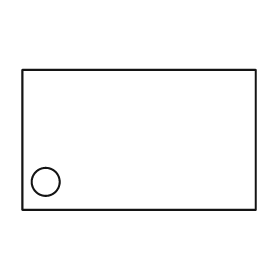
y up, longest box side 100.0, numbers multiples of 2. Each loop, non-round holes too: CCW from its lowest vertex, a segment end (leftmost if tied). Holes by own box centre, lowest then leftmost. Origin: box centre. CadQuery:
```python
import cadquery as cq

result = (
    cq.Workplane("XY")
    .moveTo(-50.0, -30.0)
    .lineTo(50.0, -30.0)
    .lineTo(50.0, 30.0)
    .lineTo(-50.0, 30.0)
    .close()
    .moveTo(-40.0, -18.0)
    .circle(6.0)
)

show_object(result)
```